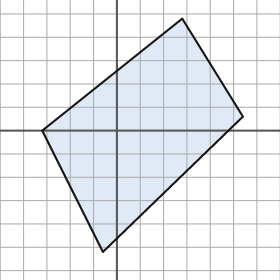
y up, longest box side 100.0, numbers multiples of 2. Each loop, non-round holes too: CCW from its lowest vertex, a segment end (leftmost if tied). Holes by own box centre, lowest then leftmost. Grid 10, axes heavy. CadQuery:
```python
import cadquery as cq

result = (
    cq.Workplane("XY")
    .moveTo(-6.0, -52.0)
    .lineTo(54.0, 6.0)
    .lineTo(28.0, 48.0)
    .lineTo(-32.0, 0.0)
    .close()
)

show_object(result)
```